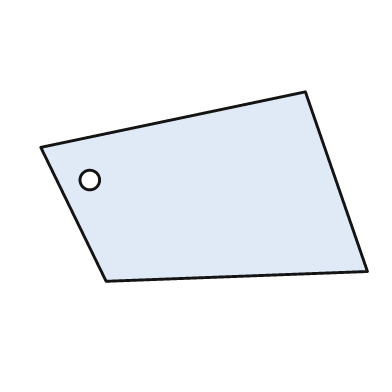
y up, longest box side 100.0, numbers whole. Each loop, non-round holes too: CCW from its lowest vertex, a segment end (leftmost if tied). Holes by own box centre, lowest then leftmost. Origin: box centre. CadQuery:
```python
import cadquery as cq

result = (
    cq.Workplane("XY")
    .moveTo(-30.0, -29.0)
    .lineTo(50.0, -26.0)
    .lineTo(31.0, 29.0)
    .lineTo(-50.0, 12.0)
    .close()
    .moveTo(-35.0, 2.0)
    .circle(3.0)
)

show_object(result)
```